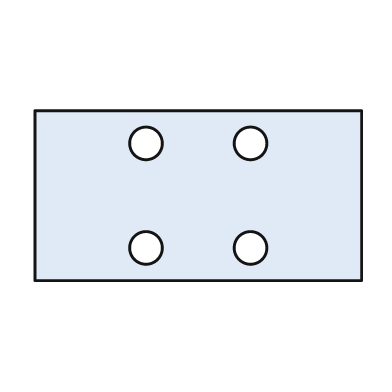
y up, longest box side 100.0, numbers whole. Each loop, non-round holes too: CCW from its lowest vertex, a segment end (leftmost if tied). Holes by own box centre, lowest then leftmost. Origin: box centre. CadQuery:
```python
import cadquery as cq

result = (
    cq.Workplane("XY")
    .moveTo(-50.0, -26.0)
    .lineTo(50.0, -26.0)
    .lineTo(50.0, 26.0)
    .lineTo(-50.0, 26.0)
    .close()
    .moveTo(-16.0, -16.0)
    .circle(5.0)
    .moveTo(16.0, -16.0)
    .circle(5.0)
    .moveTo(-16.0, 16.0)
    .circle(5.0)
    .moveTo(16.0, 16.0)
    .circle(5.0)
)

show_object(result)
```